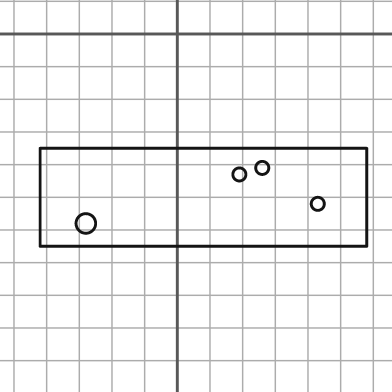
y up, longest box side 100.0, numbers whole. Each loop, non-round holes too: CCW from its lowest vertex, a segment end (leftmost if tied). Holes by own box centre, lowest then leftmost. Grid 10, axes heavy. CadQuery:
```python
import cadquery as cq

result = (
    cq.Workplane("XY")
    .moveTo(-42.0, -65.0)
    .lineTo(58.0, -65.0)
    .lineTo(58.0, -35.0)
    .lineTo(-42.0, -35.0)
    .close()
    .moveTo(-28.0, -58.0)
    .circle(3.0)
    .moveTo(43.0, -52.0)
    .circle(2.0)
    .moveTo(19.0, -43.0)
    .circle(2.0)
    .moveTo(26.0, -41.0)
    .circle(2.0)
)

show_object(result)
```